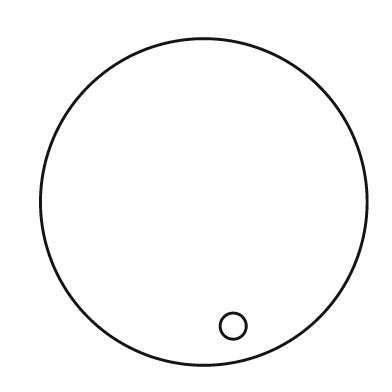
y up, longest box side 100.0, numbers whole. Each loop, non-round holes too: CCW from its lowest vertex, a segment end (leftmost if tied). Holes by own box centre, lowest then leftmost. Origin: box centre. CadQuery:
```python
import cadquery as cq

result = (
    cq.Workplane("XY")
    .moveTo(0.0, 0.0)
    .circle(50.0)
    .moveTo(9.0, -38.0)
    .circle(4.0)
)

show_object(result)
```